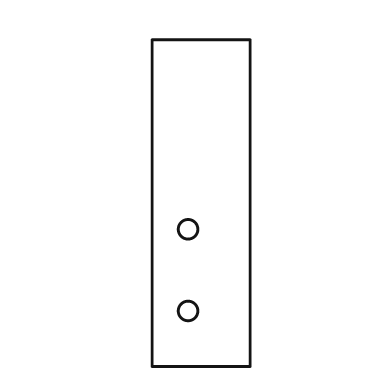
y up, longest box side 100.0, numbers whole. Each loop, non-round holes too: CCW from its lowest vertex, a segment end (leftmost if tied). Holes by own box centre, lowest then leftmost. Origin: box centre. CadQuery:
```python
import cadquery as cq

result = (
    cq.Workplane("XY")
    .moveTo(-15.0, -50.0)
    .lineTo(15.0, -50.0)
    .lineTo(15.0, 50.0)
    .lineTo(-15.0, 50.0)
    .close()
    .moveTo(-4.0, -33.0)
    .circle(3.0)
    .moveTo(-4.0, -8.0)
    .circle(3.0)
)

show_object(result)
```